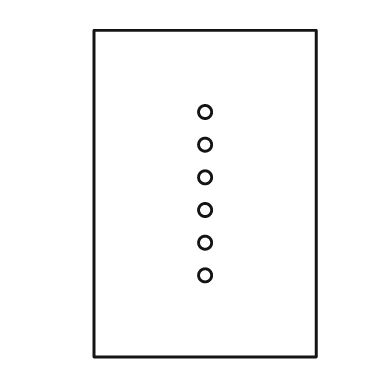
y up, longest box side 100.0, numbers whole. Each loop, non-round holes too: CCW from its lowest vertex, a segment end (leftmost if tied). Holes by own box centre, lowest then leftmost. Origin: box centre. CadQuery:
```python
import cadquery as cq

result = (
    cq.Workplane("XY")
    .moveTo(-34.0, -50.0)
    .lineTo(34.0, -50.0)
    .lineTo(34.0, 50.0)
    .lineTo(-34.0, 50.0)
    .close()
    .moveTo(0.0, -25.0)
    .circle(2.0)
    .moveTo(0.0, -15.0)
    .circle(2.0)
    .moveTo(0.0, -5.0)
    .circle(2.0)
    .moveTo(0.0, 5.0)
    .circle(2.0)
    .moveTo(0.0, 15.0)
    .circle(2.0)
    .moveTo(0.0, 25.0)
    .circle(2.0)
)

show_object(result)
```